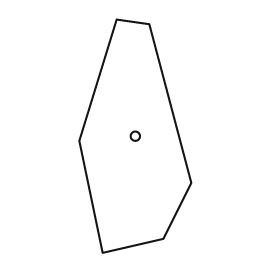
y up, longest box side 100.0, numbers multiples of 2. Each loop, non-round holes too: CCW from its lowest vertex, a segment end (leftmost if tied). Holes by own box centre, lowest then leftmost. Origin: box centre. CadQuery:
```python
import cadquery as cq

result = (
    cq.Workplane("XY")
    .moveTo(-14.0, -50.0)
    .lineTo(12.0, -44.0)
    .lineTo(24.0, -20.0)
    .lineTo(6.0, 48.0)
    .lineTo(-8.0, 50.0)
    .lineTo(-24.0, -2.0)
    .close()
    .moveTo(0.0, 0.0)
    .circle(2.0)
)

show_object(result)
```